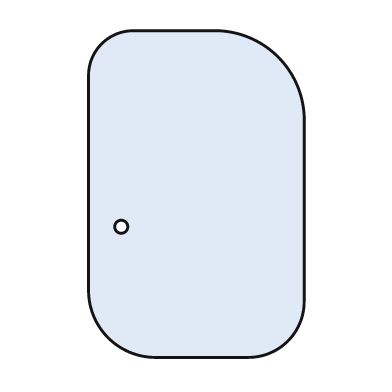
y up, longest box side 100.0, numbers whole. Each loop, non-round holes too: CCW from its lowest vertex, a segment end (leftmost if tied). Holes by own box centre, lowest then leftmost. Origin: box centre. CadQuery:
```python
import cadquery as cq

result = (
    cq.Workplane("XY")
    .moveTo(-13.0, -50.0)
    .lineTo(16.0, -50.0)
    .threePointArc((28.0, -45.0), (33.0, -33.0))
    .lineTo(33.0, 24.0)
    .threePointArc((25.0, 42.0), (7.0, 50.0))
    .lineTo(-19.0, 50.0)
    .threePointArc((-29.0, 46.0), (-33.0, 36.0))
    .lineTo(-33.0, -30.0)
    .threePointArc((-27.0, -44.0), (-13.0, -50.0))
    .close()
    .moveTo(-23.0, -10.0)
    .circle(2.0)
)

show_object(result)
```